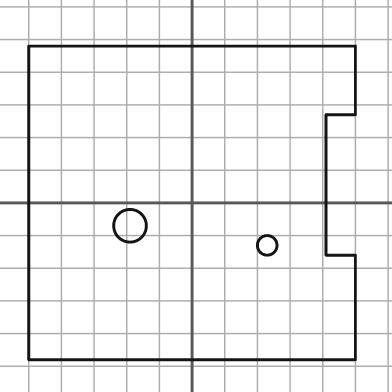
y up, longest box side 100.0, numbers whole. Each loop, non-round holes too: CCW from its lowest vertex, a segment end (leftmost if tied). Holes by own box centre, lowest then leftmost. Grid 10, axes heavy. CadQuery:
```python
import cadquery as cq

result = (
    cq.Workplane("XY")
    .moveTo(-50.0, -48.0)
    .lineTo(50.0, -48.0)
    .lineTo(50.0, -16.0)
    .lineTo(41.0, -16.0)
    .lineTo(41.0, 27.0)
    .lineTo(50.0, 27.0)
    .lineTo(50.0, 48.0)
    .lineTo(-50.0, 48.0)
    .close()
    .moveTo(23.0, -13.0)
    .circle(3.0)
    .moveTo(-19.0, -7.0)
    .circle(5.0)
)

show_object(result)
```